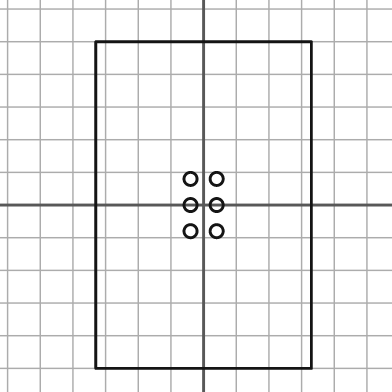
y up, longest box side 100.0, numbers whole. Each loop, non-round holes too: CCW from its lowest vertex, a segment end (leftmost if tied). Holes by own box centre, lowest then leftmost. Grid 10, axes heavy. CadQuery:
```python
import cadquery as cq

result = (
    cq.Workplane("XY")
    .moveTo(-33.0, -50.0)
    .lineTo(33.0, -50.0)
    .lineTo(33.0, 50.0)
    .lineTo(-33.0, 50.0)
    .close()
    .moveTo(-4.0, -8.0)
    .circle(2.0)
    .moveTo(4.0, -8.0)
    .circle(2.0)
    .moveTo(-4.0, 0.0)
    .circle(2.0)
    .moveTo(4.0, 0.0)
    .circle(2.0)
    .moveTo(-4.0, 8.0)
    .circle(2.0)
    .moveTo(4.0, 8.0)
    .circle(2.0)
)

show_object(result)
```